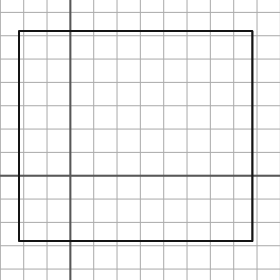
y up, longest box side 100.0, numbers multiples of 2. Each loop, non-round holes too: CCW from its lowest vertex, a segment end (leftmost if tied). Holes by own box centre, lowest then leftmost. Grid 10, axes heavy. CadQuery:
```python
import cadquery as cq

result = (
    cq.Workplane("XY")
    .moveTo(-22.0, -28.0)
    .lineTo(78.0, -28.0)
    .lineTo(78.0, 62.0)
    .lineTo(-22.0, 62.0)
    .close()
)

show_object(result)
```